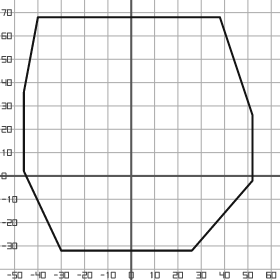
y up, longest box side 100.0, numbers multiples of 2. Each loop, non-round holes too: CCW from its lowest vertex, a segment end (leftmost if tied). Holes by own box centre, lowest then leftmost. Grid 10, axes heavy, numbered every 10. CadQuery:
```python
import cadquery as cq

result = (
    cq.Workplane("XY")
    .moveTo(-30.0, -32.0)
    .lineTo(26.0, -32.0)
    .lineTo(52.0, -2.0)
    .lineTo(52.0, 26.0)
    .lineTo(38.0, 68.0)
    .lineTo(-40.0, 68.0)
    .lineTo(-46.0, 36.0)
    .lineTo(-46.0, 2.0)
    .close()
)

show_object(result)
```